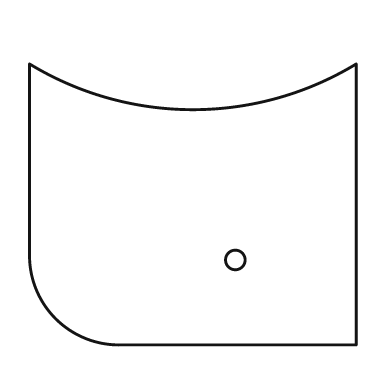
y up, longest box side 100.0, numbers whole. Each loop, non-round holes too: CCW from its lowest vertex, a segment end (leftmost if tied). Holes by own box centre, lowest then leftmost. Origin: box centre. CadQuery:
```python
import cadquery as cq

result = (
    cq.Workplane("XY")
    .moveTo(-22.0, -43.0)
    .lineTo(50.0, -43.0)
    .lineTo(50.0, 43.0)
    .threePointArc((0.0, 29.0), (-50.0, 43.0))
    .lineTo(-50.0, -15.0)
    .threePointArc((-42.0, -35.0), (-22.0, -43.0))
    .close()
    .moveTo(13.0, -17.0)
    .circle(3.0)
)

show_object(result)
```